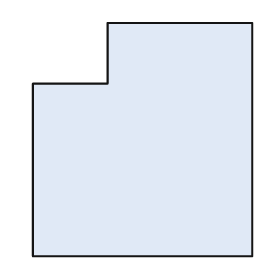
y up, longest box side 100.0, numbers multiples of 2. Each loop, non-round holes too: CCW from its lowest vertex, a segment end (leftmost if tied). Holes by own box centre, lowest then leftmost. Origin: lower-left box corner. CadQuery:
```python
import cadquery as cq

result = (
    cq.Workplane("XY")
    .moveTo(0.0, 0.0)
    .lineTo(94.0, 0.0)
    .lineTo(94.0, 100.0)
    .lineTo(32.0, 100.0)
    .lineTo(32.0, 74.0)
    .lineTo(0.0, 74.0)
    .close()
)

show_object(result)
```